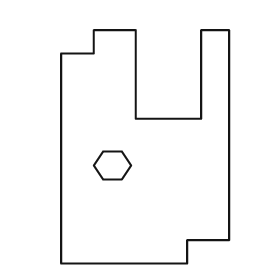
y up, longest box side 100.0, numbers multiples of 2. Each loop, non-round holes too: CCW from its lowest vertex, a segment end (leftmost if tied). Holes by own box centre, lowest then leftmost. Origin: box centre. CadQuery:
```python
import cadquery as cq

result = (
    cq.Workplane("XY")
    .moveTo(-36.0, -50.0)
    .lineTo(18.0, -50.0)
    .lineTo(18.0, -40.0)
    .lineTo(36.0, -40.0)
    .lineTo(36.0, 50.0)
    .lineTo(24.0, 50.0)
    .lineTo(24.0, 12.0)
    .lineTo(-4.0, 12.0)
    .lineTo(-4.0, 50.0)
    .lineTo(-22.0, 50.0)
    .lineTo(-22.0, 40.0)
    .lineTo(-36.0, 40.0)
    .close()
    .moveTo(-18.0, -14.0)
    .lineTo(-10.0, -14.0)
    .lineTo(-6.0, -8.0)
    .lineTo(-10.0, -2.0)
    .lineTo(-18.0, -2.0)
    .lineTo(-22.0, -8.0)
    .close()
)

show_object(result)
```